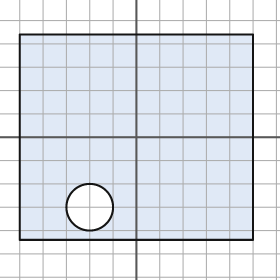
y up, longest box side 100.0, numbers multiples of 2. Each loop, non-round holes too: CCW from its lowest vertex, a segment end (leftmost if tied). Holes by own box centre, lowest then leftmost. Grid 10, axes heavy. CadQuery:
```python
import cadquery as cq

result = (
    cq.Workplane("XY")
    .moveTo(-50.0, -44.0)
    .lineTo(50.0, -44.0)
    .lineTo(50.0, 44.0)
    .lineTo(-50.0, 44.0)
    .close()
    .moveTo(-20.0, -30.0)
    .circle(10.0)
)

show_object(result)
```